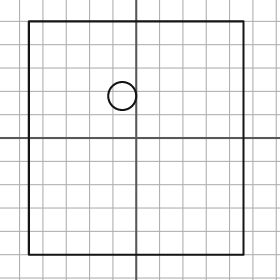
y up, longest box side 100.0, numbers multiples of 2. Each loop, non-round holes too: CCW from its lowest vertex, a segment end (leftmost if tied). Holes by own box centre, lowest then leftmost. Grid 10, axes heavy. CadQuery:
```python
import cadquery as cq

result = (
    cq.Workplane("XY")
    .moveTo(-46.0, -50.0)
    .lineTo(46.0, -50.0)
    .lineTo(46.0, 50.0)
    .lineTo(-46.0, 50.0)
    .close()
    .moveTo(-6.0, 18.0)
    .circle(6.0)
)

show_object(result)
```